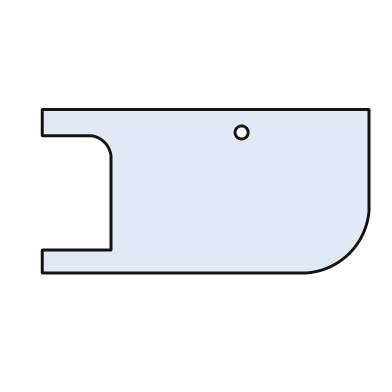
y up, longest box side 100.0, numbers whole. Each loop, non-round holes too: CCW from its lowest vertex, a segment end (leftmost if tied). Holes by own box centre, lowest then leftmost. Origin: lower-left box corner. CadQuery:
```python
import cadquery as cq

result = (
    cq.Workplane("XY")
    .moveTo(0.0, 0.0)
    .lineTo(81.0, 0.0)
    .threePointArc((94.0, 6.0), (100.0, 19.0))
    .lineTo(100.0, 50.0)
    .lineTo(0.0, 50.0)
    .lineTo(0.0, 42.0)
    .lineTo(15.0, 42.0)
    .threePointArc((19.0, 40.0), (21.0, 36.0))
    .lineTo(21.0, 7.0)
    .lineTo(0.0, 7.0)
    .close()
    .moveTo(61.0, 43.0)
    .circle(2.0)
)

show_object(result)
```